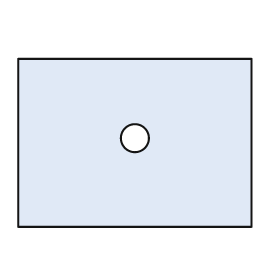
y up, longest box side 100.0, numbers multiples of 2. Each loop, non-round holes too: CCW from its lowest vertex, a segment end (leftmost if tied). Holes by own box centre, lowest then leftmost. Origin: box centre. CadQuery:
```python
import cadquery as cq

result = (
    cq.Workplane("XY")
    .moveTo(-50.0, -36.0)
    .lineTo(50.0, -36.0)
    .lineTo(50.0, 36.0)
    .lineTo(-50.0, 36.0)
    .close()
    .moveTo(0.0, 2.0)
    .circle(6.0)
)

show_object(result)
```